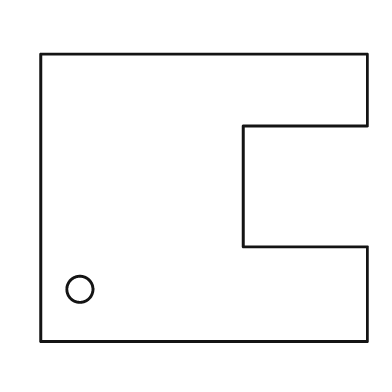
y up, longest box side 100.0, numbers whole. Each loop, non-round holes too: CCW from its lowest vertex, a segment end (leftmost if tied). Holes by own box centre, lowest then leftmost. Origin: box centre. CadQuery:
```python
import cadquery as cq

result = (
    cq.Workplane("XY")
    .moveTo(-50.0, -44.0)
    .lineTo(50.0, -44.0)
    .lineTo(50.0, -15.0)
    .lineTo(12.0, -15.0)
    .lineTo(12.0, 22.0)
    .lineTo(50.0, 22.0)
    .lineTo(50.0, 44.0)
    .lineTo(-50.0, 44.0)
    .close()
    .moveTo(-38.0, -28.0)
    .circle(4.0)
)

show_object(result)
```